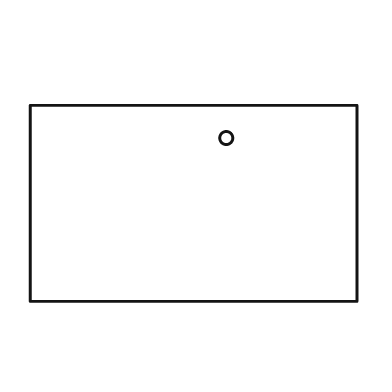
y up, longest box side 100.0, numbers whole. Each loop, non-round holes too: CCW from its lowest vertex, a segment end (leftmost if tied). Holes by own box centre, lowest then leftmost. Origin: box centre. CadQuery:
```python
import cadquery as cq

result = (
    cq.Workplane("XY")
    .moveTo(-50.0, -30.0)
    .lineTo(50.0, -30.0)
    .lineTo(50.0, 30.0)
    .lineTo(-50.0, 30.0)
    .close()
    .moveTo(10.0, 20.0)
    .circle(2.0)
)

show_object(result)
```